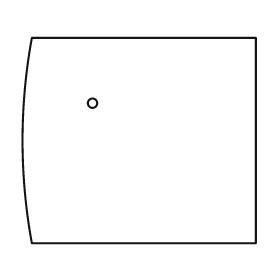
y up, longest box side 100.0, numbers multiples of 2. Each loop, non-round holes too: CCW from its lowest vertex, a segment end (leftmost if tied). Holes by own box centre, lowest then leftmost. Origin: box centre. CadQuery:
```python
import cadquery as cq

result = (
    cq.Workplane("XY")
    .moveTo(-46.0, -44.0)
    .lineTo(50.0, -44.0)
    .lineTo(50.0, 44.0)
    .lineTo(-46.0, 44.0)
    .threePointArc((-50.0, 0.0), (-46.0, -44.0))
    .close()
    .moveTo(-20.0, 16.0)
    .circle(2.0)
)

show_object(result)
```